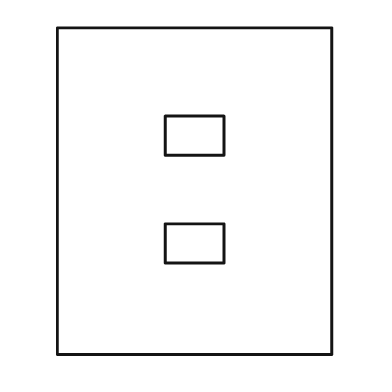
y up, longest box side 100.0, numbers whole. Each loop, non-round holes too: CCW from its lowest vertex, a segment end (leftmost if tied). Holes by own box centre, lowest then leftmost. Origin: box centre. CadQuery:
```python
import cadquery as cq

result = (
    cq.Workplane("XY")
    .moveTo(-42.0, -50.0)
    .lineTo(42.0, -50.0)
    .lineTo(42.0, 50.0)
    .lineTo(-42.0, 50.0)
    .close()
    .moveTo(-9.0, -22.0)
    .lineTo(9.0, -22.0)
    .lineTo(9.0, -10.0)
    .lineTo(-9.0, -10.0)
    .close()
    .moveTo(-9.0, 11.0)
    .lineTo(9.0, 11.0)
    .lineTo(9.0, 23.0)
    .lineTo(-9.0, 23.0)
    .close()
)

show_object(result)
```